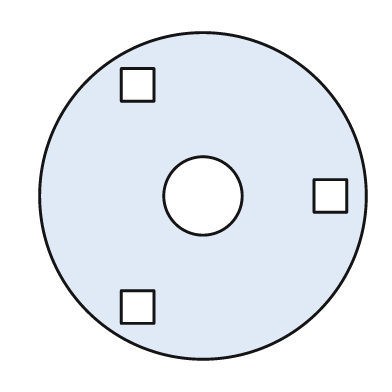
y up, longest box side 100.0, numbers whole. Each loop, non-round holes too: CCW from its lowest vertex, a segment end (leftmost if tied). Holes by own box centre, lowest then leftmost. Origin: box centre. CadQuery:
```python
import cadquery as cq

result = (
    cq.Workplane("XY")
    .moveTo(0.0, 0.0)
    .circle(50.0)
    .moveTo(-25.0, -39.0)
    .lineTo(-15.0, -39.0)
    .lineTo(-15.0, -29.0)
    .lineTo(-25.0, -29.0)
    .close()
    .moveTo(0.0, 0.0)
    .circle(12.0)
    .moveTo(34.0, -5.0)
    .lineTo(44.0, -5.0)
    .lineTo(44.0, 5.0)
    .lineTo(34.0, 5.0)
    .close()
    .moveTo(-25.0, 29.0)
    .lineTo(-15.0, 29.0)
    .lineTo(-15.0, 39.0)
    .lineTo(-25.0, 39.0)
    .close()
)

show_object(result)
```